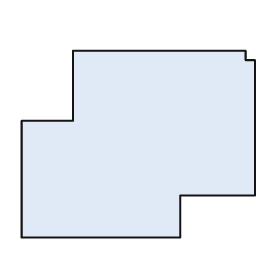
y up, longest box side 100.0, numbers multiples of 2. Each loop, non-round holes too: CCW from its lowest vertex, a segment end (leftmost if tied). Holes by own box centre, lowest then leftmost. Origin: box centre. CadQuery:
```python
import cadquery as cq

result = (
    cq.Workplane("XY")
    .moveTo(-50.0, -40.0)
    .lineTo(18.0, -40.0)
    .lineTo(18.0, -22.0)
    .lineTo(50.0, -22.0)
    .lineTo(50.0, 36.0)
    .lineTo(46.0, 36.0)
    .lineTo(46.0, 40.0)
    .lineTo(-28.0, 40.0)
    .lineTo(-28.0, 10.0)
    .lineTo(-50.0, 10.0)
    .close()
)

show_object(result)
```